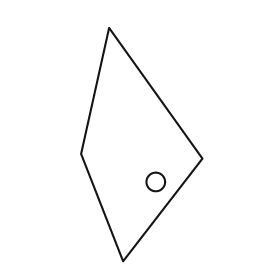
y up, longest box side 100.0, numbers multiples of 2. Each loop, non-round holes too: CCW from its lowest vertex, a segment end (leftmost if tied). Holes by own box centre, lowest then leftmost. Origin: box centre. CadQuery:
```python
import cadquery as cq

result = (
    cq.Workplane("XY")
    .moveTo(-8.0, -50.0)
    .lineTo(26.0, -6.0)
    .lineTo(-14.0, 50.0)
    .lineTo(-26.0, -4.0)
    .close()
    .moveTo(6.0, -16.0)
    .circle(4.0)
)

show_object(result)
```